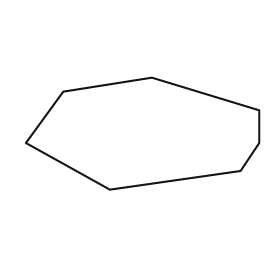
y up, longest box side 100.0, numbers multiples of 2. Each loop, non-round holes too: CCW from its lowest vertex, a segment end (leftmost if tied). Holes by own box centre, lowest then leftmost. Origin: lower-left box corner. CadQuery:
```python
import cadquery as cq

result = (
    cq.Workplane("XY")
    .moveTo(36.0, 0.0)
    .lineTo(92.0, 8.0)
    .lineTo(100.0, 20.0)
    .lineTo(100.0, 34.0)
    .lineTo(54.0, 48.0)
    .lineTo(16.0, 42.0)
    .lineTo(0.0, 20.0)
    .close()
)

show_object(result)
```